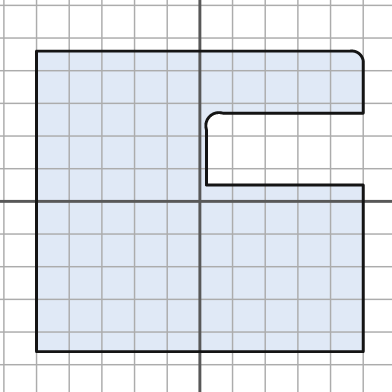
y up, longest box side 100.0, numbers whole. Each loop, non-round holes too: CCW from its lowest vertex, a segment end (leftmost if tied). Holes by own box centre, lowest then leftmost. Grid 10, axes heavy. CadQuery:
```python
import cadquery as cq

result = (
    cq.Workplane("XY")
    .moveTo(-50.0, -46.0)
    .lineTo(50.0, -46.0)
    .lineTo(50.0, 5.0)
    .lineTo(2.0, 5.0)
    .lineTo(2.0, 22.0)
    .threePointArc((3.0, 26.0), (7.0, 27.0))
    .lineTo(50.0, 27.0)
    .lineTo(50.0, 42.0)
    .threePointArc((49.0, 45.0), (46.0, 46.0))
    .lineTo(-50.0, 46.0)
    .close()
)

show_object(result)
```